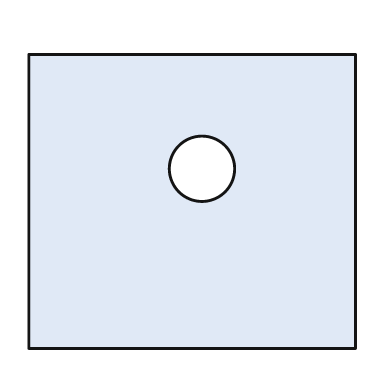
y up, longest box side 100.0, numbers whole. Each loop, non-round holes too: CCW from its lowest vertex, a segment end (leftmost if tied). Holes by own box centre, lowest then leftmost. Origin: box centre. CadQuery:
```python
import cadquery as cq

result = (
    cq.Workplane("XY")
    .moveTo(-50.0, -45.0)
    .lineTo(50.0, -45.0)
    .lineTo(50.0, 45.0)
    .lineTo(-50.0, 45.0)
    .close()
    .moveTo(3.0, 10.0)
    .circle(10.0)
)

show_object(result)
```